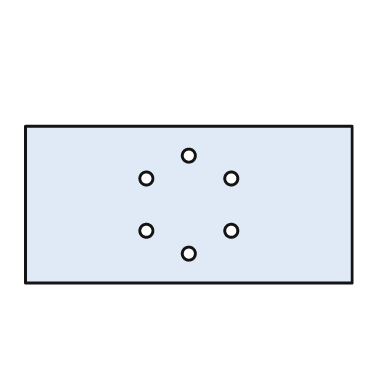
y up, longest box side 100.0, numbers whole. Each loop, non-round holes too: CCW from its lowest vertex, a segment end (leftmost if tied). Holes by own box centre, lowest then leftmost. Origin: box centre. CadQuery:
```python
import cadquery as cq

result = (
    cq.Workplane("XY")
    .moveTo(-50.0, -24.0)
    .lineTo(50.0, -24.0)
    .lineTo(50.0, 24.0)
    .lineTo(-50.0, 24.0)
    .close()
    .moveTo(0.0, -15.0)
    .circle(2.0)
    .moveTo(-13.0, -8.0)
    .circle(2.0)
    .moveTo(13.0, -8.0)
    .circle(2.0)
    .moveTo(-13.0, 8.0)
    .circle(2.0)
    .moveTo(13.0, 8.0)
    .circle(2.0)
    .moveTo(0.0, 15.0)
    .circle(2.0)
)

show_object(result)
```